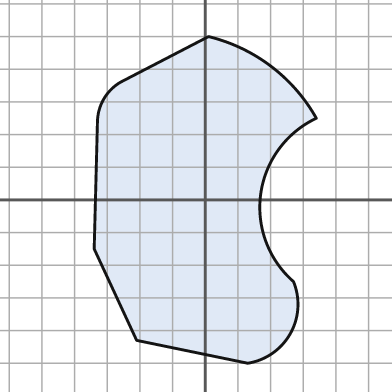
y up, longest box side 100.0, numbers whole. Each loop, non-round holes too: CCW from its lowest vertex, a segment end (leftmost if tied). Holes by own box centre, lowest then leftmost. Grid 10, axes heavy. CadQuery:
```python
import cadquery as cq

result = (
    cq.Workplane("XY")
    .moveTo(13.0, -50.0)
    .threePointArc((26.0, -41.0), (27.0, -25.0))
    .threePointArc((17.0, 2.0), (34.0, 25.0))
    .threePointArc((20.0, 41.0), (1.0, 50.0))
    .lineTo(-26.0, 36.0)
    .threePointArc((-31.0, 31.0), (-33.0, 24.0))
    .lineTo(-34.0, -15.0)
    .lineTo(-21.0, -43.0)
    .close()
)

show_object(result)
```